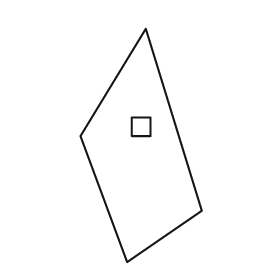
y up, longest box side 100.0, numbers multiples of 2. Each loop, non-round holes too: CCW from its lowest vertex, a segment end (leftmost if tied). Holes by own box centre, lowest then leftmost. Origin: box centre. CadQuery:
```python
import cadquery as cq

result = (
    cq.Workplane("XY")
    .moveTo(-6.0, -50.0)
    .lineTo(26.0, -28.0)
    .lineTo(2.0, 50.0)
    .lineTo(-26.0, 4.0)
    .close()
    .moveTo(-4.0, 4.0)
    .lineTo(4.0, 4.0)
    .lineTo(4.0, 12.0)
    .lineTo(-4.0, 12.0)
    .close()
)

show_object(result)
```